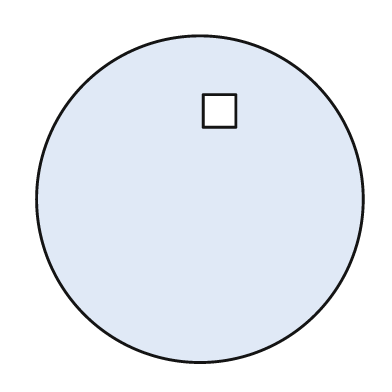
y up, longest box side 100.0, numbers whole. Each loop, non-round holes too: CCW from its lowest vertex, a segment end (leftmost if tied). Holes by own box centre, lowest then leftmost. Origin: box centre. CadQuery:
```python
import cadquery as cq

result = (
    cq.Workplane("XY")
    .moveTo(0.0, 0.0)
    .circle(50.0)
    .moveTo(1.0, 22.0)
    .lineTo(11.0, 22.0)
    .lineTo(11.0, 32.0)
    .lineTo(1.0, 32.0)
    .close()
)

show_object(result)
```